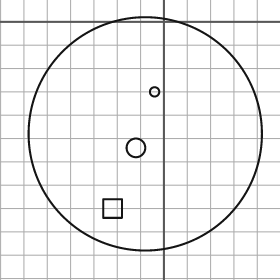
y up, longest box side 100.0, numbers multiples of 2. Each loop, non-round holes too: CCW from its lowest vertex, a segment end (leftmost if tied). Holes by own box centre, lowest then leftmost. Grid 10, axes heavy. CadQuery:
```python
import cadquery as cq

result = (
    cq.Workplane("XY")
    .moveTo(-8.0, -48.0)
    .circle(50.0)
    .moveTo(-26.0, -84.0)
    .lineTo(-18.0, -84.0)
    .lineTo(-18.0, -76.0)
    .lineTo(-26.0, -76.0)
    .close()
    .moveTo(-12.0, -54.0)
    .circle(4.0)
    .moveTo(-4.0, -30.0)
    .circle(2.0)
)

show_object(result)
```